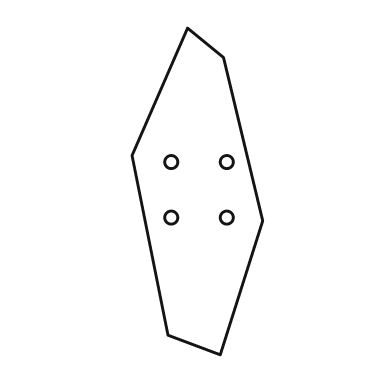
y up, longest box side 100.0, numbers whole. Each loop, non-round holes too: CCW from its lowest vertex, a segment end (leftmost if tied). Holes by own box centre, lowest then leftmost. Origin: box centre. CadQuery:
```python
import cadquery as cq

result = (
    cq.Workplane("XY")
    .moveTo(7.0, -50.0)
    .lineTo(20.0, -9.0)
    .lineTo(8.0, 41.0)
    .lineTo(-3.0, 50.0)
    .lineTo(-20.0, 11.0)
    .lineTo(-9.0, -44.0)
    .close()
    .moveTo(-8.0, -8.0)
    .circle(2.0)
    .moveTo(9.0, -8.0)
    .circle(2.0)
    .moveTo(-8.0, 9.0)
    .circle(2.0)
    .moveTo(9.0, 9.0)
    .circle(2.0)
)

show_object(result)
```